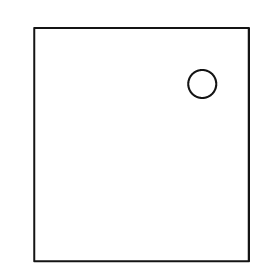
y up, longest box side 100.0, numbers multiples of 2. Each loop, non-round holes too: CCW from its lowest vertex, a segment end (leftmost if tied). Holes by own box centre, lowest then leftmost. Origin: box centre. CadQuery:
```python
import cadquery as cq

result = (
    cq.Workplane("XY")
    .moveTo(-46.0, -50.0)
    .lineTo(46.0, -50.0)
    .lineTo(46.0, 50.0)
    .lineTo(-46.0, 50.0)
    .close()
    .moveTo(26.0, 26.0)
    .circle(6.0)
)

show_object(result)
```